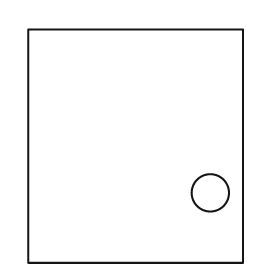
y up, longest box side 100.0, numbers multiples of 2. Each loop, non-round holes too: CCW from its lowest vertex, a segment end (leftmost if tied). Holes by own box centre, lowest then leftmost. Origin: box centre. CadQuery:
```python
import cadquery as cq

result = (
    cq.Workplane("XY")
    .moveTo(-46.0, -50.0)
    .lineTo(46.0, -50.0)
    .lineTo(46.0, 50.0)
    .lineTo(-46.0, 50.0)
    .close()
    .moveTo(32.0, -20.0)
    .circle(8.0)
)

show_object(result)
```